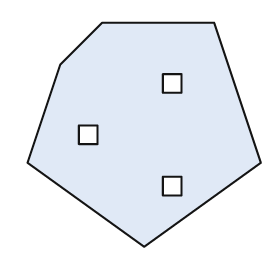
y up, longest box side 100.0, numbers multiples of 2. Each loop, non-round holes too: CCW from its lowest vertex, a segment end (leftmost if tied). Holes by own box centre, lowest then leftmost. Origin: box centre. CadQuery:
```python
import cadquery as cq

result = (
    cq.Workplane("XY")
    .moveTo(0.0, -48.0)
    .lineTo(50.0, -12.0)
    .lineTo(30.0, 48.0)
    .lineTo(-18.0, 48.0)
    .lineTo(-36.0, 30.0)
    .lineTo(-50.0, -12.0)
    .close()
    .moveTo(8.0, -26.0)
    .lineTo(16.0, -26.0)
    .lineTo(16.0, -18.0)
    .lineTo(8.0, -18.0)
    .close()
    .moveTo(-28.0, -4.0)
    .lineTo(-20.0, -4.0)
    .lineTo(-20.0, 4.0)
    .lineTo(-28.0, 4.0)
    .close()
    .moveTo(8.0, 18.0)
    .lineTo(16.0, 18.0)
    .lineTo(16.0, 26.0)
    .lineTo(8.0, 26.0)
    .close()
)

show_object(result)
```